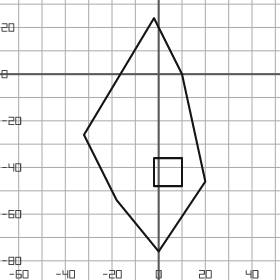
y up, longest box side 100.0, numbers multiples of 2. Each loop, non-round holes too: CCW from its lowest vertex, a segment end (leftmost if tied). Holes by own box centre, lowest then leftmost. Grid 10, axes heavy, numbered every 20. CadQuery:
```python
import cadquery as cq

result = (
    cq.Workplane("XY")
    .moveTo(0.0, -76.0)
    .lineTo(20.0, -46.0)
    .lineTo(10.0, 0.0)
    .lineTo(-2.0, 24.0)
    .lineTo(-32.0, -26.0)
    .lineTo(-18.0, -54.0)
    .close()
    .moveTo(-2.0, -48.0)
    .lineTo(10.0, -48.0)
    .lineTo(10.0, -36.0)
    .lineTo(-2.0, -36.0)
    .close()
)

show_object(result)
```